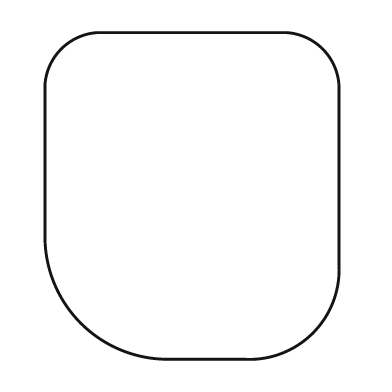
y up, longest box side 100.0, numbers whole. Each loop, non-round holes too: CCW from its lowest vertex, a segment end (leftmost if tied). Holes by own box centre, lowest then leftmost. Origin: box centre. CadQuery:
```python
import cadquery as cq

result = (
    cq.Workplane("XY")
    .moveTo(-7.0, -50.0)
    .lineTo(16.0, -50.0)
    .threePointArc((37.0, -42.0), (45.0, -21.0))
    .lineTo(45.0, 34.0)
    .threePointArc((40.0, 45.0), (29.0, 50.0))
    .lineTo(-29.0, 50.0)
    .threePointArc((-40.0, 45.0), (-45.0, 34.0))
    .lineTo(-45.0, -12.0)
    .threePointArc((-34.0, -39.0), (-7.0, -50.0))
    .close()
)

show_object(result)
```